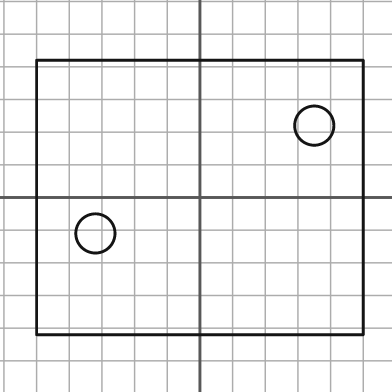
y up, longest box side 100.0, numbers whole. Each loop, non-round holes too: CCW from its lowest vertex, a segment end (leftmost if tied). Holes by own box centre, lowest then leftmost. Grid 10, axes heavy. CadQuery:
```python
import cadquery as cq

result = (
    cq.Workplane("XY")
    .moveTo(-50.0, -42.0)
    .lineTo(50.0, -42.0)
    .lineTo(50.0, 42.0)
    .lineTo(-50.0, 42.0)
    .close()
    .moveTo(-32.0, -11.0)
    .circle(6.0)
    .moveTo(35.0, 22.0)
    .circle(6.0)
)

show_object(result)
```